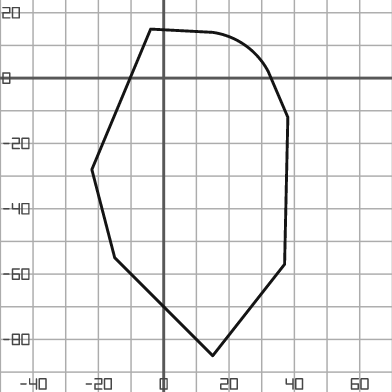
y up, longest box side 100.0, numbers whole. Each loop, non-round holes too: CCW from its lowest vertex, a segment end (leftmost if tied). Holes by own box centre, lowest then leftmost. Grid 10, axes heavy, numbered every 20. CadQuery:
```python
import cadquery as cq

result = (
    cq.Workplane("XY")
    .moveTo(15.0, -85.0)
    .lineTo(37.0, -57.0)
    .lineTo(38.0, -12.0)
    .lineTo(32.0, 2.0)
    .threePointArc((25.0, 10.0), (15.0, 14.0))
    .lineTo(-4.0, 15.0)
    .lineTo(-22.0, -28.0)
    .lineTo(-15.0, -55.0)
    .close()
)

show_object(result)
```